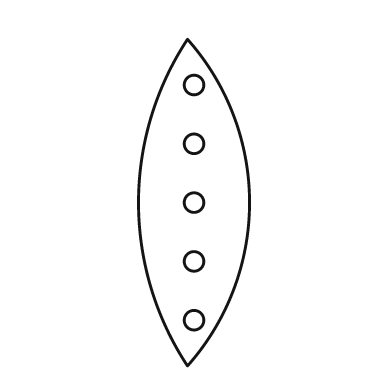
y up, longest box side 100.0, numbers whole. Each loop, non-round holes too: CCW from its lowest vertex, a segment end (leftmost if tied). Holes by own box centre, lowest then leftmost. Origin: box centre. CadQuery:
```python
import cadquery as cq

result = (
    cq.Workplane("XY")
    .moveTo(-2.0, -50.0)
    .threePointArc((17.0, 0.0), (-2.0, 50.0))
    .threePointArc((-17.0, 0.0), (-2.0, -50.0))
    .close()
    .moveTo(0.0, -36.0)
    .circle(3.0)
    .moveTo(0.0, -18.0)
    .circle(3.0)
    .moveTo(0.0, 0.0)
    .circle(3.0)
    .moveTo(0.0, 18.0)
    .circle(3.0)
    .moveTo(0.0, 36.0)
    .circle(3.0)
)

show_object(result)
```